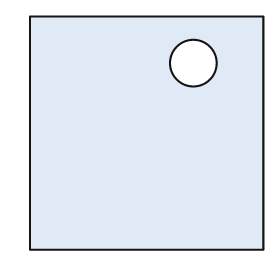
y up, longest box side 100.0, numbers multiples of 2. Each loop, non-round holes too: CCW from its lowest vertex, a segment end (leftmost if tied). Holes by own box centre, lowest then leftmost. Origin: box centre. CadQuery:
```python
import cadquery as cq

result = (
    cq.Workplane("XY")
    .moveTo(-50.0, -50.0)
    .lineTo(50.0, -50.0)
    .lineTo(50.0, 50.0)
    .lineTo(-50.0, 50.0)
    .close()
    .moveTo(20.0, 30.0)
    .circle(10.0)
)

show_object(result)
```